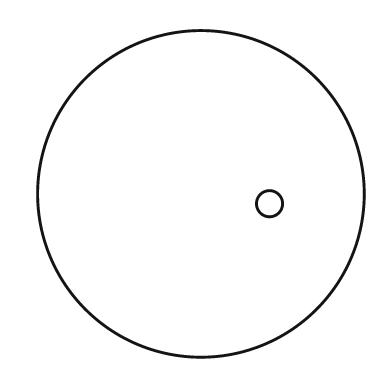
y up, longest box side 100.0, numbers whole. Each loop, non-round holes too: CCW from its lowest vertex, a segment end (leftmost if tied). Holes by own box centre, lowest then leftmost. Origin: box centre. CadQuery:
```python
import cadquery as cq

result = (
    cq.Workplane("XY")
    .moveTo(0.0, 0.0)
    .circle(50.0)
    .moveTo(21.0, -3.0)
    .circle(4.0)
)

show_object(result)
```